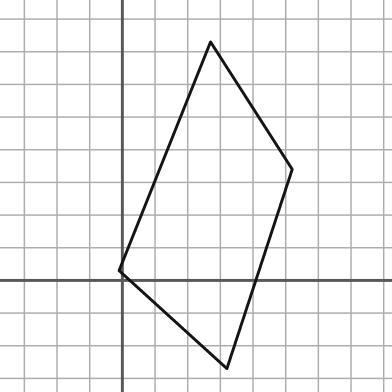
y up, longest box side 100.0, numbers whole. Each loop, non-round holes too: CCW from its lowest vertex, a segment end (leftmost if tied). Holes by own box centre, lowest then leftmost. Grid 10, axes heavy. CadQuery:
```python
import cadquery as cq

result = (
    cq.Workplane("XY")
    .moveTo(32.0, -27.0)
    .lineTo(52.0, 34.0)
    .lineTo(27.0, 73.0)
    .lineTo(-1.0, 3.0)
    .close()
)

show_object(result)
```